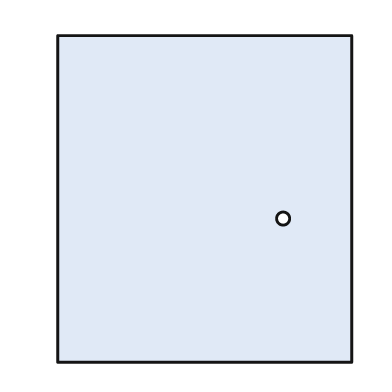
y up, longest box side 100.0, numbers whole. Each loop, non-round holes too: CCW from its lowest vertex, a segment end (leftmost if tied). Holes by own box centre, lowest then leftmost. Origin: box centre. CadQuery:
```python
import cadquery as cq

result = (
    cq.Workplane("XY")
    .moveTo(-45.0, -50.0)
    .lineTo(45.0, -50.0)
    .lineTo(45.0, 50.0)
    .lineTo(-45.0, 50.0)
    .close()
    .moveTo(24.0, -6.0)
    .circle(2.0)
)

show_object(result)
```